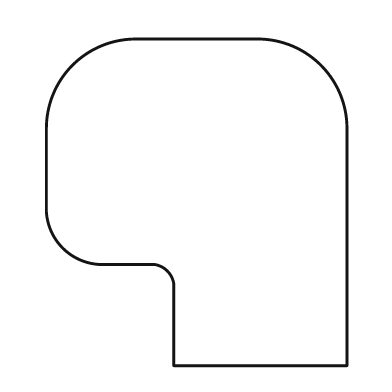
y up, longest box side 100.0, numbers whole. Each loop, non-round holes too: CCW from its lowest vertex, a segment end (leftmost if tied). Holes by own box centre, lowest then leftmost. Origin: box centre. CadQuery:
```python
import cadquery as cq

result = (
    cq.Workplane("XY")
    .moveTo(-7.0, -50.0)
    .lineTo(46.0, -50.0)
    .lineTo(46.0, 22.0)
    .threePointArc((38.0, 42.0), (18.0, 50.0))
    .lineTo(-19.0, 50.0)
    .threePointArc((-38.0, 42.0), (-46.0, 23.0))
    .lineTo(-46.0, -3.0)
    .threePointArc((-41.0, -14.0), (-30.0, -19.0))
    .lineTo(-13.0, -19.0)
    .threePointArc((-9.0, -21.0), (-7.0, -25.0))
    .close()
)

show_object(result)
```